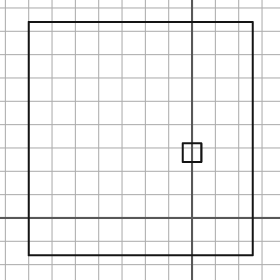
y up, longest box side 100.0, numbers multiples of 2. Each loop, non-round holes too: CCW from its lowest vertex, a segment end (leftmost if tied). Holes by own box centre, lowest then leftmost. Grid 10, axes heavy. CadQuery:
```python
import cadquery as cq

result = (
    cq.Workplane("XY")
    .moveTo(-70.0, -16.0)
    .lineTo(26.0, -16.0)
    .lineTo(26.0, 84.0)
    .lineTo(-70.0, 84.0)
    .close()
    .moveTo(-4.0, 24.0)
    .lineTo(4.0, 24.0)
    .lineTo(4.0, 32.0)
    .lineTo(-4.0, 32.0)
    .close()
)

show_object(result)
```